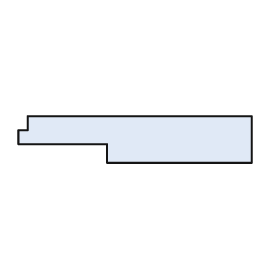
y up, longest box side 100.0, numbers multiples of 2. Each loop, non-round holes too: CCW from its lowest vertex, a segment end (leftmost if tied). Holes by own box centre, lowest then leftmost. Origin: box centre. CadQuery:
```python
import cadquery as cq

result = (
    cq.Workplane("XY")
    .moveTo(-12.0, -10.0)
    .lineTo(50.0, -10.0)
    .lineTo(50.0, 10.0)
    .lineTo(-46.0, 10.0)
    .lineTo(-46.0, 4.0)
    .lineTo(-50.0, 4.0)
    .lineTo(-50.0, -2.0)
    .lineTo(-12.0, -2.0)
    .close()
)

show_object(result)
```